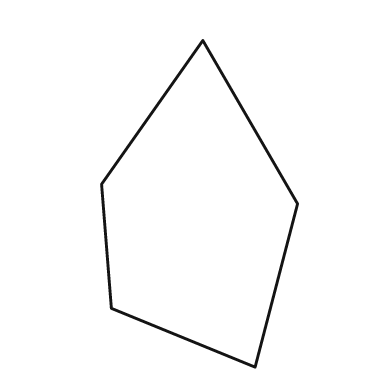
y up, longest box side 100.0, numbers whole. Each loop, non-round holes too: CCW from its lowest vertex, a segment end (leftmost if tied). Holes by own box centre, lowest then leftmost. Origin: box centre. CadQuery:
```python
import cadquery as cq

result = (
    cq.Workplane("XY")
    .moveTo(17.0, -50.0)
    .lineTo(30.0, 0.0)
    .lineTo(1.0, 50.0)
    .lineTo(-30.0, 6.0)
    .lineTo(-27.0, -32.0)
    .close()
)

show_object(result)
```